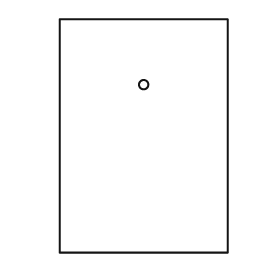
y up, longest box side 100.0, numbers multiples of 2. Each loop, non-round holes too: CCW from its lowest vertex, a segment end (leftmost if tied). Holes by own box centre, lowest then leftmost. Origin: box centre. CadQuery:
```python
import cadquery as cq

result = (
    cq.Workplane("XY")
    .moveTo(-36.0, -50.0)
    .lineTo(36.0, -50.0)
    .lineTo(36.0, 50.0)
    .lineTo(-36.0, 50.0)
    .close()
    .moveTo(0.0, 22.0)
    .circle(2.0)
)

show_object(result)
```